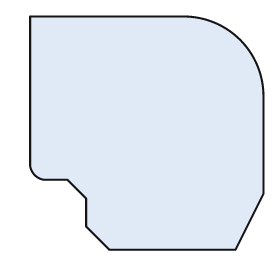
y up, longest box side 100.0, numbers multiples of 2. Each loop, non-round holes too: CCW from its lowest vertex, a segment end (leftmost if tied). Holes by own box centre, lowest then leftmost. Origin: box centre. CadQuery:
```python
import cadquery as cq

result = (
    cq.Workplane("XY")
    .moveTo(-16.0, -50.0)
    .lineTo(38.0, -50.0)
    .lineTo(50.0, -26.0)
    .lineTo(50.0, 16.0)
    .threePointArc((40.0, 40.0), (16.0, 50.0))
    .lineTo(-50.0, 50.0)
    .lineTo(-50.0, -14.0)
    .threePointArc((-48.0, -18.0), (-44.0, -20.0))
    .lineTo(-34.0, -20.0)
    .lineTo(-26.0, -28.0)
    .lineTo(-26.0, -40.0)
    .close()
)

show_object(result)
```